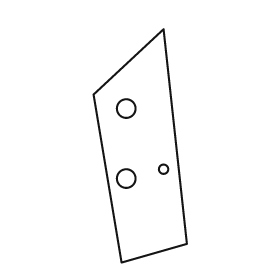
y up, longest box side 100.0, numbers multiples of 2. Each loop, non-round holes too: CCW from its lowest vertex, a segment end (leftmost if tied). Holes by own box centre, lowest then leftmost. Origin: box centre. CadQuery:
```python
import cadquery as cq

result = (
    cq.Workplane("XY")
    .moveTo(-8.0, -50.0)
    .lineTo(20.0, -42.0)
    .lineTo(10.0, 50.0)
    .lineTo(-20.0, 22.0)
    .close()
    .moveTo(-6.0, -14.0)
    .circle(4.0)
    .moveTo(10.0, -10.0)
    .circle(2.0)
    .moveTo(-6.0, 16.0)
    .circle(4.0)
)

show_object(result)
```